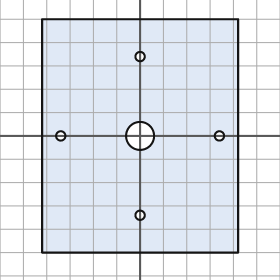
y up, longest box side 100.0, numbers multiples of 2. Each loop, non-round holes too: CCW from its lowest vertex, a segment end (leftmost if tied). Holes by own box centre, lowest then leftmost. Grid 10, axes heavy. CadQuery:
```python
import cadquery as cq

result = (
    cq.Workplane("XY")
    .moveTo(-42.0, -50.0)
    .lineTo(42.0, -50.0)
    .lineTo(42.0, 50.0)
    .lineTo(-42.0, 50.0)
    .close()
    .moveTo(0.0, -34.0)
    .circle(2.0)
    .moveTo(-34.0, 0.0)
    .circle(2.0)
    .moveTo(0.0, 0.0)
    .circle(6.0)
    .moveTo(34.0, 0.0)
    .circle(2.0)
    .moveTo(0.0, 34.0)
    .circle(2.0)
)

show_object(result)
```